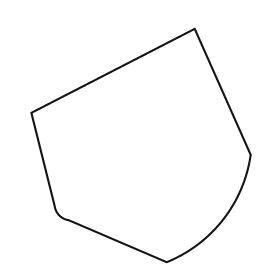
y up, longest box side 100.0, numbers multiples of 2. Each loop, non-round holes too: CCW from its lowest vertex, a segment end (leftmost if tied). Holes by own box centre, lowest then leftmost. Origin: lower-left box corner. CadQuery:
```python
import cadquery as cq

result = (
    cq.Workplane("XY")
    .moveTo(58.0, 0.0)
    .threePointArc((82.0, 18.0), (94.0, 46.0))
    .lineTo(70.0, 100.0)
    .lineTo(0.0, 64.0)
    .lineTo(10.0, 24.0)
    .threePointArc((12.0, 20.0), (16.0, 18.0))
    .close()
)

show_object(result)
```